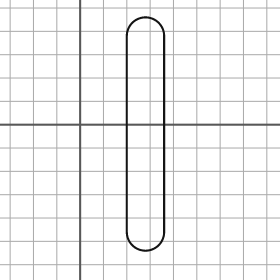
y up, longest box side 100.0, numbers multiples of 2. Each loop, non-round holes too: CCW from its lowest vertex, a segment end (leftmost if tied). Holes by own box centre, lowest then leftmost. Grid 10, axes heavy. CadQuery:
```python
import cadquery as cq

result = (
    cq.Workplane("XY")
    .moveTo(20.0, -46.0)
    .threePointArc((28.0, -54.0), (36.0, -46.0))
    .lineTo(36.0, 38.0)
    .threePointArc((28.0, 46.0), (20.0, 38.0))
    .close()
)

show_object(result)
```